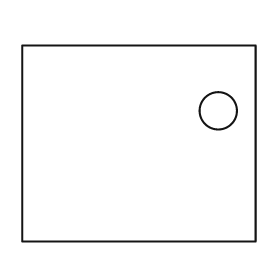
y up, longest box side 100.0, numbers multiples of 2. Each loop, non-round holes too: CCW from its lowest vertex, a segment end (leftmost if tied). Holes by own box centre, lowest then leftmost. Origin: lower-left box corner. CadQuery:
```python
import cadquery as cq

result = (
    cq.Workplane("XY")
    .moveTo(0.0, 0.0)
    .lineTo(100.0, 0.0)
    .lineTo(100.0, 84.0)
    .lineTo(0.0, 84.0)
    .close()
    .moveTo(84.0, 56.0)
    .circle(8.0)
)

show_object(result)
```